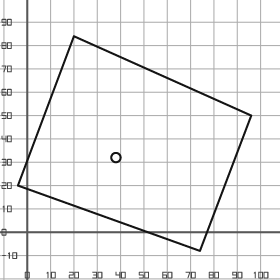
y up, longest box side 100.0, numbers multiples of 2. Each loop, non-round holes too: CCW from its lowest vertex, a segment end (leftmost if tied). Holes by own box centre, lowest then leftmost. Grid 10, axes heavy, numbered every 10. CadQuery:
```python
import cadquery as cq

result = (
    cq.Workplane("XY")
    .moveTo(74.0, -8.0)
    .lineTo(96.0, 50.0)
    .lineTo(20.0, 84.0)
    .lineTo(-4.0, 20.0)
    .close()
    .moveTo(38.0, 32.0)
    .circle(2.0)
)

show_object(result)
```